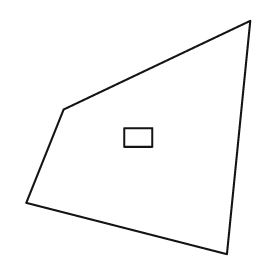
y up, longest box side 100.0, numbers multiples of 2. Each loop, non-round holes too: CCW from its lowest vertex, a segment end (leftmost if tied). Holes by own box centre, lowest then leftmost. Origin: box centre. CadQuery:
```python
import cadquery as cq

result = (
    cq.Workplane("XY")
    .moveTo(38.0, -50.0)
    .lineTo(48.0, 50.0)
    .lineTo(-32.0, 12.0)
    .lineTo(-48.0, -28.0)
    .close()
    .moveTo(-6.0, -4.0)
    .lineTo(6.0, -4.0)
    .lineTo(6.0, 4.0)
    .lineTo(-6.0, 4.0)
    .close()
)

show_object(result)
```